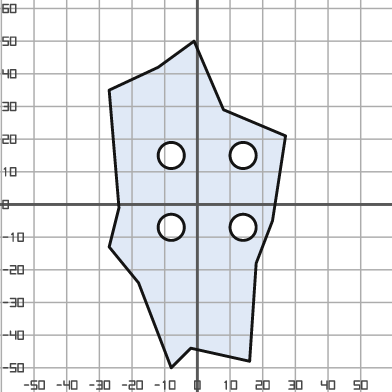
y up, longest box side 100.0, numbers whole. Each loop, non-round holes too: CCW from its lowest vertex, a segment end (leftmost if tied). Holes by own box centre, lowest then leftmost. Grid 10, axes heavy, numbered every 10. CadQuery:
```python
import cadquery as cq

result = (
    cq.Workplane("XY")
    .moveTo(-8.0, -50.0)
    .lineTo(-2.0, -44.0)
    .lineTo(16.0, -48.0)
    .lineTo(18.0, -18.0)
    .lineTo(23.0, -5.0)
    .lineTo(27.0, 21.0)
    .lineTo(8.0, 29.0)
    .lineTo(-1.0, 50.0)
    .lineTo(-12.0, 42.0)
    .lineTo(-27.0, 35.0)
    .lineTo(-24.0, -1.0)
    .lineTo(-27.0, -13.0)
    .lineTo(-18.0, -24.0)
    .close()
    .moveTo(-8.0, -7.0)
    .circle(4.0)
    .moveTo(14.0, -7.0)
    .circle(4.0)
    .moveTo(-8.0, 15.0)
    .circle(4.0)
    .moveTo(14.0, 15.0)
    .circle(4.0)
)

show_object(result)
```